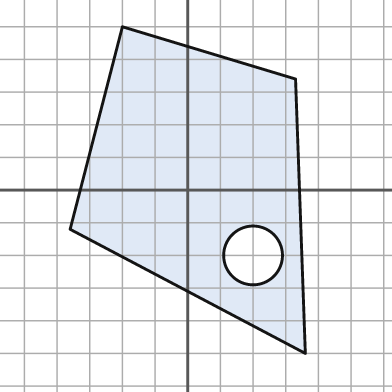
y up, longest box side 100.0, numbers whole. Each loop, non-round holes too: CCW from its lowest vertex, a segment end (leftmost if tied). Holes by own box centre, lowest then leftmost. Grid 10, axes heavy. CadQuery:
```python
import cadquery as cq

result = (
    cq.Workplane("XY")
    .moveTo(36.0, -50.0)
    .lineTo(33.0, 34.0)
    .lineTo(-20.0, 50.0)
    .lineTo(-36.0, -12.0)
    .close()
    .moveTo(20.0, -20.0)
    .circle(9.0)
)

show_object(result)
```